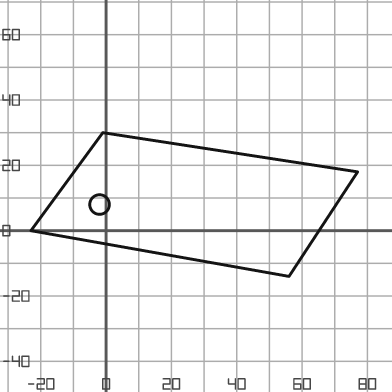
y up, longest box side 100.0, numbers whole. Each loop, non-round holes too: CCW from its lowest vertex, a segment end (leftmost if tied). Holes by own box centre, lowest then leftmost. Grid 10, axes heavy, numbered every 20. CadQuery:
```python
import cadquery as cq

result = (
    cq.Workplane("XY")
    .moveTo(56.0, -14.0)
    .lineTo(77.0, 18.0)
    .lineTo(-1.0, 30.0)
    .lineTo(-23.0, 0.0)
    .close()
    .moveTo(-2.0, 8.0)
    .circle(3.0)
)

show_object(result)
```